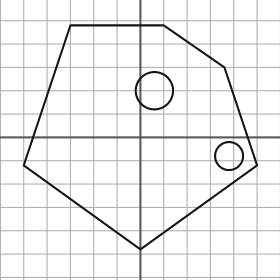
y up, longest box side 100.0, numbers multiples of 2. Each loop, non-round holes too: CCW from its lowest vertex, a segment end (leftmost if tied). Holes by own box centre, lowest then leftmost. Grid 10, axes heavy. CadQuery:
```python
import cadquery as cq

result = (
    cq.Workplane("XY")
    .moveTo(0.0, -48.0)
    .lineTo(50.0, -12.0)
    .lineTo(36.0, 30.0)
    .lineTo(10.0, 48.0)
    .lineTo(-30.0, 48.0)
    .lineTo(-50.0, -12.0)
    .close()
    .moveTo(38.0, -8.0)
    .circle(6.0)
    .moveTo(6.0, 20.0)
    .circle(8.0)
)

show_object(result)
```